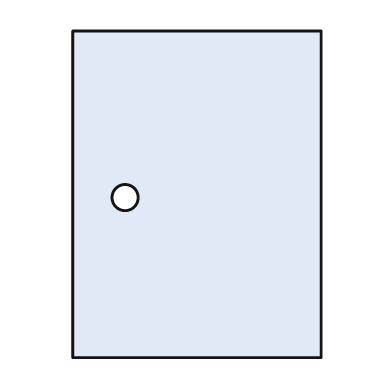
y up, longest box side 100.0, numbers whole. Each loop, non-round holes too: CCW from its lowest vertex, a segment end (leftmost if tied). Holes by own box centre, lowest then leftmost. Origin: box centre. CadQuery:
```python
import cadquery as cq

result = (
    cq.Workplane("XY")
    .moveTo(-38.0, -50.0)
    .lineTo(38.0, -50.0)
    .lineTo(38.0, 50.0)
    .lineTo(-38.0, 50.0)
    .close()
    .moveTo(-22.0, -1.0)
    .circle(4.0)
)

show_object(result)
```